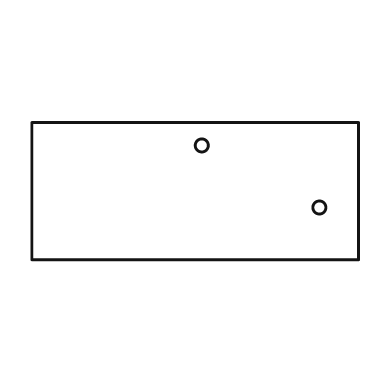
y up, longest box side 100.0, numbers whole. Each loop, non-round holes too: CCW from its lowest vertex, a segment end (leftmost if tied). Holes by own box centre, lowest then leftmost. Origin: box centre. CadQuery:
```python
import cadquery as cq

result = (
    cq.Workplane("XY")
    .moveTo(-50.0, -21.0)
    .lineTo(50.0, -21.0)
    .lineTo(50.0, 21.0)
    .lineTo(-50.0, 21.0)
    .close()
    .moveTo(38.0, -5.0)
    .circle(2.0)
    .moveTo(2.0, 14.0)
    .circle(2.0)
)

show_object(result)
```